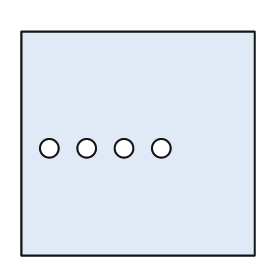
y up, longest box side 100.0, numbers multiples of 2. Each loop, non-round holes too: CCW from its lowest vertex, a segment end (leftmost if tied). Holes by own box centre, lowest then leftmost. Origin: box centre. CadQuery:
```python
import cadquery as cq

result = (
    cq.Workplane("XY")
    .moveTo(-50.0, -48.0)
    .lineTo(50.0, -48.0)
    .lineTo(50.0, 48.0)
    .lineTo(-50.0, 48.0)
    .close()
    .moveTo(-38.0, -2.0)
    .circle(4.0)
    .moveTo(-22.0, -2.0)
    .circle(4.0)
    .moveTo(-6.0, -2.0)
    .circle(4.0)
    .moveTo(10.0, -2.0)
    .circle(4.0)
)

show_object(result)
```